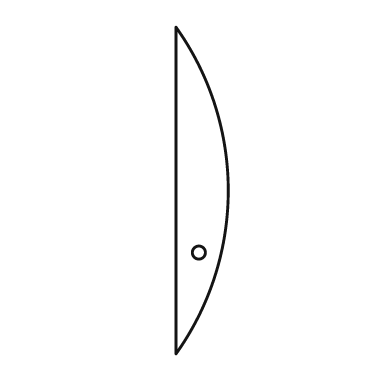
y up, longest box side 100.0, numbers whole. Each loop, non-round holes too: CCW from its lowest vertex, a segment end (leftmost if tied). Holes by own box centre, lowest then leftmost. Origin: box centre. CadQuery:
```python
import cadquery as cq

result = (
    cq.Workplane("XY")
    .moveTo(-8.0, -50.0)
    .threePointArc((8.0, 0.0), (-8.0, 50.0))
    .close()
    .moveTo(-1.0, -19.0)
    .circle(2.0)
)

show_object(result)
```